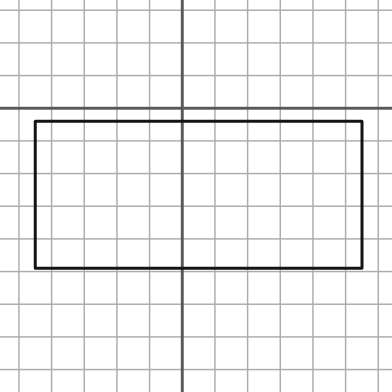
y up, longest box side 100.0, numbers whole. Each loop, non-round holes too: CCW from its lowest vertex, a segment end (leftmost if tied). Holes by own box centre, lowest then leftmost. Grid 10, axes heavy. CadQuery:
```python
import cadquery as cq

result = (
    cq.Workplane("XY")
    .moveTo(-45.0, -49.0)
    .lineTo(55.0, -49.0)
    .lineTo(55.0, -4.0)
    .lineTo(-45.0, -4.0)
    .close()
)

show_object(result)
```